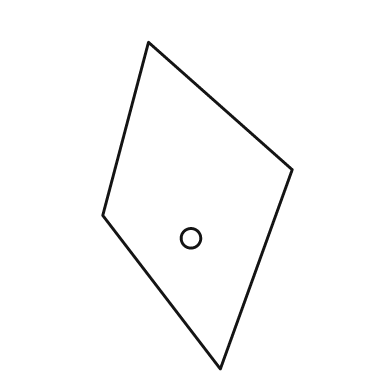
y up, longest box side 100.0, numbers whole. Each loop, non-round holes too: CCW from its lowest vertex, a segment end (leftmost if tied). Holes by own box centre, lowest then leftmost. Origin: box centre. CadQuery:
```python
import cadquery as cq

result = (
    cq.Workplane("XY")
    .moveTo(7.0, -50.0)
    .lineTo(29.0, 11.0)
    .lineTo(-15.0, 50.0)
    .lineTo(-29.0, -3.0)
    .close()
    .moveTo(-2.0, -10.0)
    .circle(3.0)
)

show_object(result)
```